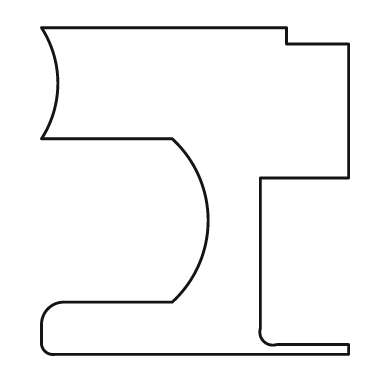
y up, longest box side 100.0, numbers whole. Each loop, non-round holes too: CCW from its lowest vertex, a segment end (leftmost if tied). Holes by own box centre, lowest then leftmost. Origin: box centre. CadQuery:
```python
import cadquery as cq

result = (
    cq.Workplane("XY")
    .moveTo(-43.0, -50.0)
    .lineTo(47.0, -50.0)
    .lineTo(47.0, -47.0)
    .lineTo(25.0, -47.0)
    .threePointArc((21.0, -46.0), (20.0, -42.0))
    .lineTo(20.0, 4.0)
    .lineTo(47.0, 4.0)
    .lineTo(47.0, 45.0)
    .lineTo(28.0, 45.0)
    .lineTo(28.0, 50.0)
    .lineTo(-47.0, 50.0)
    .threePointArc((-42.0, 33.0), (-47.0, 16.0))
    .lineTo(-7.0, 16.0)
    .threePointArc((4.0, -9.0), (-7.0, -34.0))
    .lineTo(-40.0, -34.0)
    .threePointArc((-45.0, -36.0), (-47.0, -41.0))
    .lineTo(-47.0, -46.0)
    .threePointArc((-46.0, -49.0), (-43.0, -50.0))
    .close()
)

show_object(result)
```